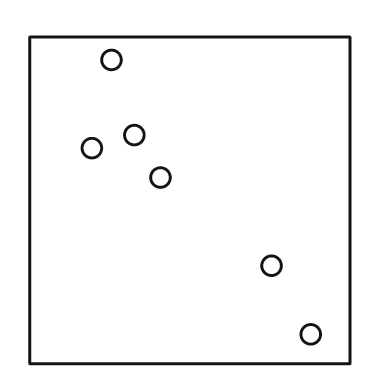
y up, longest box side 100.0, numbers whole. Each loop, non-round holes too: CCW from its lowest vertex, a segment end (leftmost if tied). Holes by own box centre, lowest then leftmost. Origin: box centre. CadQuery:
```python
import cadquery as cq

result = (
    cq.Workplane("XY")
    .moveTo(-49.0, -50.0)
    .lineTo(49.0, -50.0)
    .lineTo(49.0, 50.0)
    .lineTo(-49.0, 50.0)
    .close()
    .moveTo(37.0, -41.0)
    .circle(3.0)
    .moveTo(25.0, -20.0)
    .circle(3.0)
    .moveTo(-9.0, 7.0)
    .circle(3.0)
    .moveTo(-30.0, 16.0)
    .circle(3.0)
    .moveTo(-17.0, 20.0)
    .circle(3.0)
    .moveTo(-24.0, 43.0)
    .circle(3.0)
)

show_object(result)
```